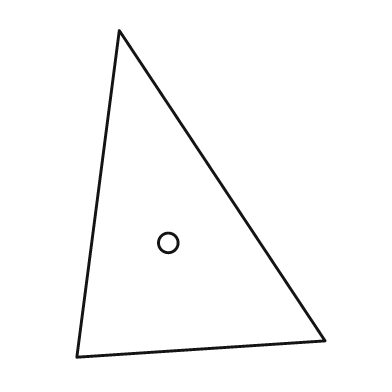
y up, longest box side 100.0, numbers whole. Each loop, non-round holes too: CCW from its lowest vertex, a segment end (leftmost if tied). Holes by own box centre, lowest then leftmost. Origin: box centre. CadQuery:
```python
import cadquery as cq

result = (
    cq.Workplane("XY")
    .moveTo(-38.0, -50.0)
    .lineTo(38.0, -45.0)
    .lineTo(-25.0, 50.0)
    .close()
    .moveTo(-10.0, -15.0)
    .circle(3.0)
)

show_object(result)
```